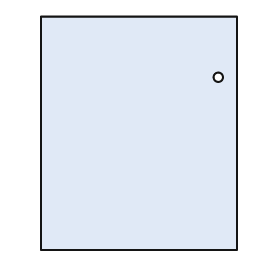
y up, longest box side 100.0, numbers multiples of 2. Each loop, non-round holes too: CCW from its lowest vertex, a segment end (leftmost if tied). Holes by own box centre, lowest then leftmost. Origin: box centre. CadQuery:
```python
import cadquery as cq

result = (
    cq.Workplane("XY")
    .moveTo(-42.0, -50.0)
    .lineTo(42.0, -50.0)
    .lineTo(42.0, 50.0)
    .lineTo(-42.0, 50.0)
    .close()
    .moveTo(34.0, 24.0)
    .circle(2.0)
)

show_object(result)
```